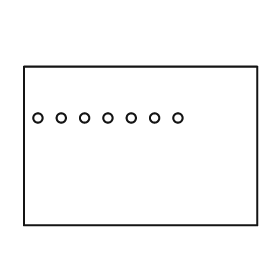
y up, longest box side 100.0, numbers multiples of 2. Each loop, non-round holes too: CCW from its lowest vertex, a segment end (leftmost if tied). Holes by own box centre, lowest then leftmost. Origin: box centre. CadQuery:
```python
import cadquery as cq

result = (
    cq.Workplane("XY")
    .moveTo(-50.0, -34.0)
    .lineTo(50.0, -34.0)
    .lineTo(50.0, 34.0)
    .lineTo(-50.0, 34.0)
    .close()
    .moveTo(-44.0, 12.0)
    .circle(2.0)
    .moveTo(-34.0, 12.0)
    .circle(2.0)
    .moveTo(-24.0, 12.0)
    .circle(2.0)
    .moveTo(-14.0, 12.0)
    .circle(2.0)
    .moveTo(-4.0, 12.0)
    .circle(2.0)
    .moveTo(6.0, 12.0)
    .circle(2.0)
    .moveTo(16.0, 12.0)
    .circle(2.0)
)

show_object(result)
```